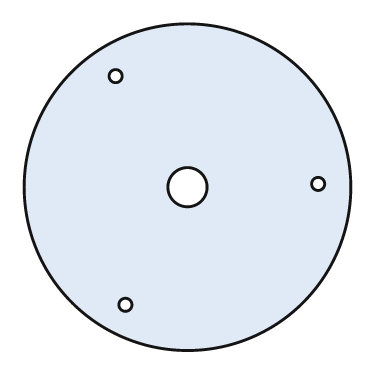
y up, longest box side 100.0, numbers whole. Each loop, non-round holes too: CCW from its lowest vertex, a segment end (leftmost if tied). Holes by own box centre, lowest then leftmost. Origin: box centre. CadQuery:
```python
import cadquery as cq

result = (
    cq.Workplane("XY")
    .moveTo(0.0, 0.0)
    .circle(50.0)
    .moveTo(-19.0, -36.0)
    .circle(2.0)
    .moveTo(0.0, 0.0)
    .circle(6.0)
    .moveTo(40.0, 1.0)
    .circle(2.0)
    .moveTo(-22.0, 34.0)
    .circle(2.0)
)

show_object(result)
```